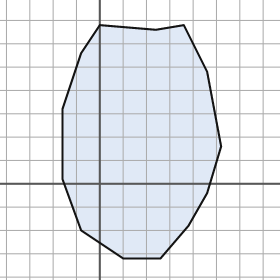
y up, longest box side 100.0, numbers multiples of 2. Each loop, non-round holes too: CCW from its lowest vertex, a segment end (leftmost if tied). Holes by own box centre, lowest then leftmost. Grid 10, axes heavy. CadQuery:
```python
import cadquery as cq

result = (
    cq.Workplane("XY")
    .moveTo(10.0, -32.0)
    .lineTo(26.0, -32.0)
    .lineTo(38.0, -18.0)
    .lineTo(46.0, -4.0)
    .lineTo(52.0, 16.0)
    .lineTo(46.0, 48.0)
    .lineTo(36.0, 68.0)
    .lineTo(24.0, 66.0)
    .lineTo(0.0, 68.0)
    .lineTo(-8.0, 56.0)
    .lineTo(-16.0, 32.0)
    .lineTo(-16.0, 2.0)
    .lineTo(-8.0, -20.0)
    .close()
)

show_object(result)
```